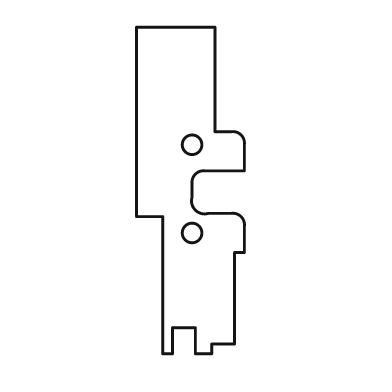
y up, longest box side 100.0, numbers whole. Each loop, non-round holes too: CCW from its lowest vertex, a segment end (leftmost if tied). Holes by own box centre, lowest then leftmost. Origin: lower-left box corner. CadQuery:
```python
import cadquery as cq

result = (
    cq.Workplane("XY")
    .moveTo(8.0, 0.0)
    .lineTo(11.0, 0.0)
    .lineTo(11.0, 8.0)
    .lineTo(18.0, 8.0)
    .lineTo(18.0, 0.0)
    .lineTo(23.0, 0.0)
    .lineTo(23.0, 3.0)
    .lineTo(30.0, 3.0)
    .lineTo(30.0, 31.0)
    .lineTo(33.0, 31.0)
    .lineTo(33.0, 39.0)
    .threePointArc((32.0, 42.0), (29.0, 43.0))
    .lineTo(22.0, 43.0)
    .threePointArc((18.0, 44.0), (17.0, 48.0))
    .lineTo(17.0, 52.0)
    .threePointArc((18.0, 55.0), (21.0, 56.0))
    .lineTo(33.0, 56.0)
    .lineTo(33.0, 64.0)
    .threePointArc((32.0, 67.0), (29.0, 68.0))
    .lineTo(24.0, 68.0)
    .lineTo(24.0, 100.0)
    .lineTo(0.0, 100.0)
    .lineTo(0.0, 42.0)
    .lineTo(8.0, 42.0)
    .close()
    .moveTo(17.0, 37.0)
    .circle(3.0)
    .moveTo(17.0, 64.0)
    .circle(3.0)
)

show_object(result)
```